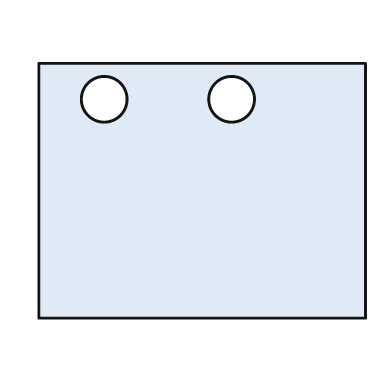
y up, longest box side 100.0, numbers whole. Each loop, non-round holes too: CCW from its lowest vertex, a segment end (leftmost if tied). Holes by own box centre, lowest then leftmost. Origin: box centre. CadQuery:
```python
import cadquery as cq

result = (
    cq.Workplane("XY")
    .moveTo(-50.0, -39.0)
    .lineTo(50.0, -39.0)
    .lineTo(50.0, 39.0)
    .lineTo(-50.0, 39.0)
    .close()
    .moveTo(-30.0, 28.0)
    .circle(7.0)
    .moveTo(9.0, 28.0)
    .circle(7.0)
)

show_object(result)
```